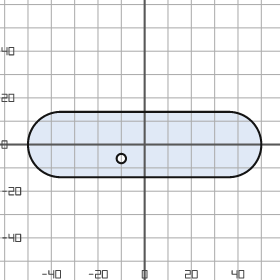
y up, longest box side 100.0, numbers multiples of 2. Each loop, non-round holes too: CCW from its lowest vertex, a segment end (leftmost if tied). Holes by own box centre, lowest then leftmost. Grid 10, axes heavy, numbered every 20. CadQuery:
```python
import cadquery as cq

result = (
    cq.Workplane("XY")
    .moveTo(-36.0, -14.0)
    .lineTo(36.0, -14.0)
    .threePointArc((50.0, 0.0), (36.0, 14.0))
    .lineTo(-36.0, 14.0)
    .threePointArc((-50.0, 0.0), (-36.0, -14.0))
    .close()
    .moveTo(-10.0, -6.0)
    .circle(2.0)
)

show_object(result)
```